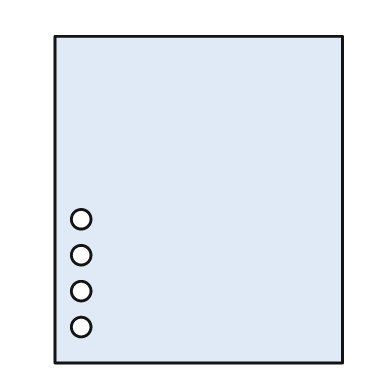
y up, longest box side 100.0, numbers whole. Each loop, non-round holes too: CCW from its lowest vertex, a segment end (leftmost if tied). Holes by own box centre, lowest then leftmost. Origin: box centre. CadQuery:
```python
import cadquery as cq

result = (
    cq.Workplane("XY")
    .moveTo(-44.0, -50.0)
    .lineTo(44.0, -50.0)
    .lineTo(44.0, 50.0)
    .lineTo(-44.0, 50.0)
    .close()
    .moveTo(-36.0, -39.0)
    .circle(3.0)
    .moveTo(-36.0, -28.0)
    .circle(3.0)
    .moveTo(-36.0, -17.0)
    .circle(3.0)
    .moveTo(-36.0, -6.0)
    .circle(3.0)
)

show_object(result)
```